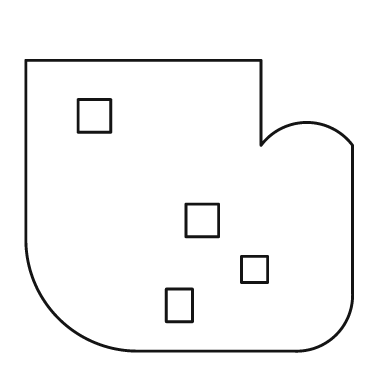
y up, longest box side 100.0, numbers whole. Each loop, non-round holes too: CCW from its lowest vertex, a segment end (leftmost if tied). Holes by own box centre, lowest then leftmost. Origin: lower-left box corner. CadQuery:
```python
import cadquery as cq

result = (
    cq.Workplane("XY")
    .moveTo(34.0, 0.0)
    .lineTo(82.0, 0.0)
    .threePointArc((95.0, 5.0), (100.0, 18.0))
    .lineTo(100.0, 63.0)
    .threePointArc((86.0, 70.0), (72.0, 63.0))
    .lineTo(72.0, 89.0)
    .lineTo(0.0, 89.0)
    .lineTo(0.0, 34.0)
    .threePointArc((10.0, 10.0), (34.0, 0.0))
    .close()
    .moveTo(43.0, 9.0)
    .lineTo(51.0, 9.0)
    .lineTo(51.0, 19.0)
    .lineTo(43.0, 19.0)
    .close()
    .moveTo(66.0, 21.0)
    .lineTo(74.0, 21.0)
    .lineTo(74.0, 29.0)
    .lineTo(66.0, 29.0)
    .close()
    .moveTo(49.0, 35.0)
    .lineTo(59.0, 35.0)
    .lineTo(59.0, 45.0)
    .lineTo(49.0, 45.0)
    .close()
    .moveTo(16.0, 67.0)
    .lineTo(26.0, 67.0)
    .lineTo(26.0, 77.0)
    .lineTo(16.0, 77.0)
    .close()
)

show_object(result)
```